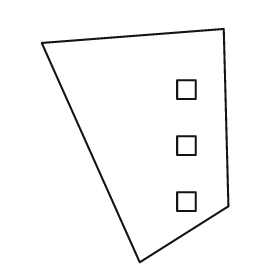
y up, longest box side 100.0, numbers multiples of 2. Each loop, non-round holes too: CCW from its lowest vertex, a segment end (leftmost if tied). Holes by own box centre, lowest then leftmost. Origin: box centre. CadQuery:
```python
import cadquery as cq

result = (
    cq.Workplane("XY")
    .moveTo(2.0, -50.0)
    .lineTo(40.0, -26.0)
    .lineTo(38.0, 50.0)
    .lineTo(-40.0, 44.0)
    .close()
    .moveTo(18.0, -28.0)
    .lineTo(26.0, -28.0)
    .lineTo(26.0, -20.0)
    .lineTo(18.0, -20.0)
    .close()
    .moveTo(18.0, -4.0)
    .lineTo(26.0, -4.0)
    .lineTo(26.0, 4.0)
    .lineTo(18.0, 4.0)
    .close()
    .moveTo(18.0, 20.0)
    .lineTo(26.0, 20.0)
    .lineTo(26.0, 28.0)
    .lineTo(18.0, 28.0)
    .close()
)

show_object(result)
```